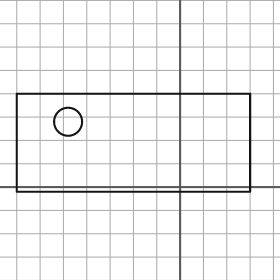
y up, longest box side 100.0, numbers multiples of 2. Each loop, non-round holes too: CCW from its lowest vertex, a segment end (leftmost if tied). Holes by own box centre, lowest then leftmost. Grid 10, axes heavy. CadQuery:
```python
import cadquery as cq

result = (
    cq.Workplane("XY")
    .moveTo(-70.0, -2.0)
    .lineTo(30.0, -2.0)
    .lineTo(30.0, 40.0)
    .lineTo(-70.0, 40.0)
    .close()
    .moveTo(-48.0, 28.0)
    .circle(6.0)
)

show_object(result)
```